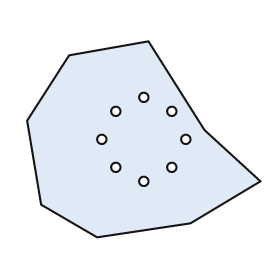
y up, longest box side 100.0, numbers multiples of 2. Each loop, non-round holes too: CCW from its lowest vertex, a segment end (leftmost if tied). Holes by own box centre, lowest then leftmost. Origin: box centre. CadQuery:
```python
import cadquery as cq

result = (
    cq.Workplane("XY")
    .moveTo(-20.0, -42.0)
    .lineTo(20.0, -36.0)
    .lineTo(50.0, -18.0)
    .lineTo(26.0, 4.0)
    .lineTo(2.0, 42.0)
    .lineTo(-32.0, 36.0)
    .lineTo(-50.0, 8.0)
    .lineTo(-44.0, -28.0)
    .close()
    .moveTo(0.0, -18.0)
    .circle(2.0)
    .moveTo(-12.0, -12.0)
    .circle(2.0)
    .moveTo(12.0, -12.0)
    .circle(2.0)
    .moveTo(-18.0, 0.0)
    .circle(2.0)
    .moveTo(18.0, 0.0)
    .circle(2.0)
    .moveTo(-12.0, 12.0)
    .circle(2.0)
    .moveTo(12.0, 12.0)
    .circle(2.0)
    .moveTo(0.0, 18.0)
    .circle(2.0)
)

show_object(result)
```